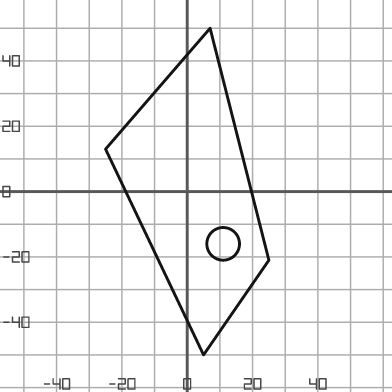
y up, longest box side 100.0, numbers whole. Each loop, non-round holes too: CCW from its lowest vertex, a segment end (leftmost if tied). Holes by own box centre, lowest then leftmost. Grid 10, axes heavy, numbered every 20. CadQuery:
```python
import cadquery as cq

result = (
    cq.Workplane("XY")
    .moveTo(5.0, -50.0)
    .lineTo(25.0, -21.0)
    .lineTo(7.0, 50.0)
    .lineTo(-25.0, 13.0)
    .close()
    .moveTo(11.0, -16.0)
    .circle(5.0)
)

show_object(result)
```